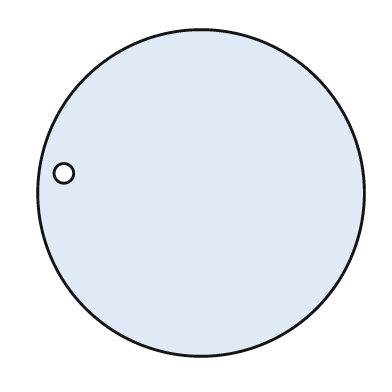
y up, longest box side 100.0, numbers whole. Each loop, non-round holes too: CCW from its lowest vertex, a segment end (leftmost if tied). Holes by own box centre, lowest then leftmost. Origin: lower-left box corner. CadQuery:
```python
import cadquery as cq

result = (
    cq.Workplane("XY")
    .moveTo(50.0, 50.0)
    .circle(50.0)
    .moveTo(8.0, 56.0)
    .circle(3.0)
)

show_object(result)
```